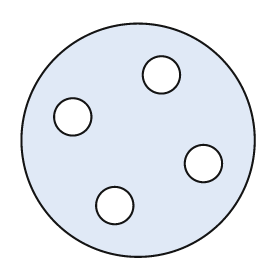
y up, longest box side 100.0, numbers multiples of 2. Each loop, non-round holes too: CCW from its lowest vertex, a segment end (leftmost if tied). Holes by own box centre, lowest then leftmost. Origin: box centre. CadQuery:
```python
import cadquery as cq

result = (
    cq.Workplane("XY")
    .moveTo(0.0, 0.0)
    .circle(50.0)
    .moveTo(-10.0, -28.0)
    .circle(8.0)
    .moveTo(28.0, -10.0)
    .circle(8.0)
    .moveTo(-28.0, 10.0)
    .circle(8.0)
    .moveTo(10.0, 28.0)
    .circle(8.0)
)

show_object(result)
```